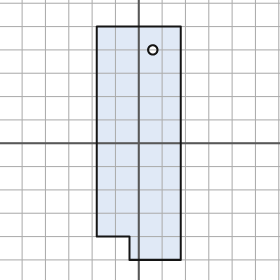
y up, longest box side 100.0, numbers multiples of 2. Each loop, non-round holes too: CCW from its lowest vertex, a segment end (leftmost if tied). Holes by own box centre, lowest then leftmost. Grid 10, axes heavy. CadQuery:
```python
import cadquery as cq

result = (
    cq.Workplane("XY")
    .moveTo(-4.0, -50.0)
    .lineTo(18.0, -50.0)
    .lineTo(18.0, 50.0)
    .lineTo(-18.0, 50.0)
    .lineTo(-18.0, -40.0)
    .lineTo(-4.0, -40.0)
    .close()
    .moveTo(6.0, 40.0)
    .circle(2.0)
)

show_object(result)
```